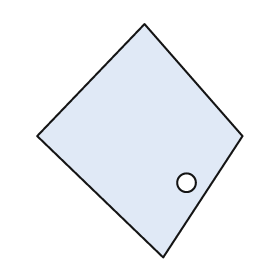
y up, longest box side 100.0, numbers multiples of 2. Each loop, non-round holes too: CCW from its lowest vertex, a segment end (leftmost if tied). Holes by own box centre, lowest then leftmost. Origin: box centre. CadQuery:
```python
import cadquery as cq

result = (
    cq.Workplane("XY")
    .moveTo(10.0, -50.0)
    .lineTo(44.0, 2.0)
    .lineTo(2.0, 50.0)
    .lineTo(-44.0, 2.0)
    .close()
    .moveTo(20.0, -18.0)
    .circle(4.0)
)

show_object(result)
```